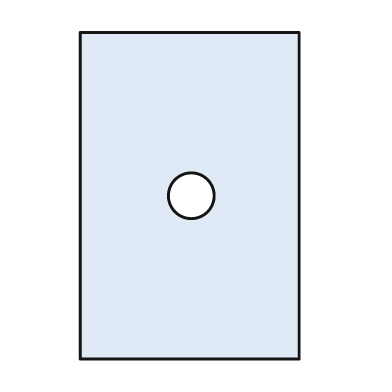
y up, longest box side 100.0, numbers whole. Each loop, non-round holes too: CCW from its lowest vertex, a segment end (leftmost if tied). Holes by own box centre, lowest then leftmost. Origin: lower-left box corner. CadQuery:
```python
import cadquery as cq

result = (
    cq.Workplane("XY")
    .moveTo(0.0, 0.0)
    .lineTo(67.0, 0.0)
    .lineTo(67.0, 100.0)
    .lineTo(0.0, 100.0)
    .close()
    .moveTo(34.0, 50.0)
    .circle(7.0)
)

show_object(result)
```